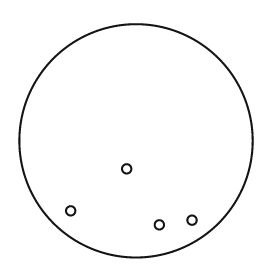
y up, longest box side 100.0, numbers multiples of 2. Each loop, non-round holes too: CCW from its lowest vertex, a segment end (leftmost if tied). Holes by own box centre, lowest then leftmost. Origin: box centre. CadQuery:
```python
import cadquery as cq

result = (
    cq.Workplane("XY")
    .moveTo(0.0, 0.0)
    .circle(50.0)
    .moveTo(10.0, -36.0)
    .circle(2.0)
    .moveTo(24.0, -34.0)
    .circle(2.0)
    .moveTo(-28.0, -30.0)
    .circle(2.0)
    .moveTo(-4.0, -12.0)
    .circle(2.0)
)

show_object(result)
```